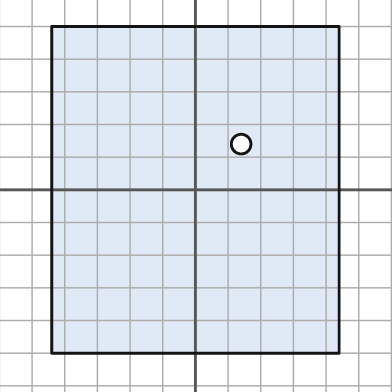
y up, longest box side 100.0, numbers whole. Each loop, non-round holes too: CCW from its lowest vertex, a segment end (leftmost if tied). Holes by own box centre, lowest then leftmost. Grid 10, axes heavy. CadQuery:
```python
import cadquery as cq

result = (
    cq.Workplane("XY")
    .moveTo(-44.0, -50.0)
    .lineTo(44.0, -50.0)
    .lineTo(44.0, 50.0)
    .lineTo(-44.0, 50.0)
    .close()
    .moveTo(14.0, 14.0)
    .circle(3.0)
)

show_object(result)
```